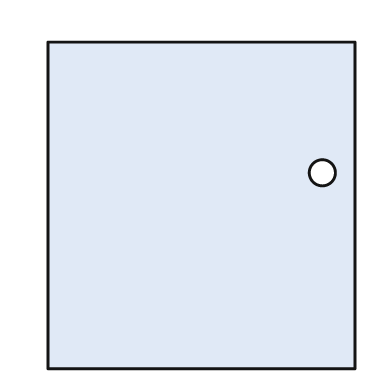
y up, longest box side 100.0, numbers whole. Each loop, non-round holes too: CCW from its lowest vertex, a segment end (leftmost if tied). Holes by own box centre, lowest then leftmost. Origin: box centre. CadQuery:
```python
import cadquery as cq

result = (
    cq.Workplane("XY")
    .moveTo(-47.0, -50.0)
    .lineTo(47.0, -50.0)
    .lineTo(47.0, 50.0)
    .lineTo(-47.0, 50.0)
    .close()
    .moveTo(37.0, 10.0)
    .circle(4.0)
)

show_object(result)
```